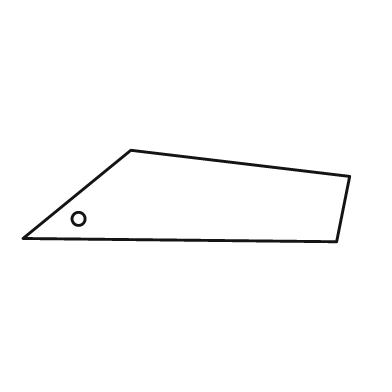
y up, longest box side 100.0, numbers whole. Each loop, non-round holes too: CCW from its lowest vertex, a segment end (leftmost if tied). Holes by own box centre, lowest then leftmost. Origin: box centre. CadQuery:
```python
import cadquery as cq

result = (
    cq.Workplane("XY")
    .moveTo(46.0, -14.0)
    .lineTo(50.0, 6.0)
    .lineTo(-17.0, 14.0)
    .lineTo(-50.0, -13.0)
    .close()
    .moveTo(-33.0, -7.0)
    .circle(2.0)
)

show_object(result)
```